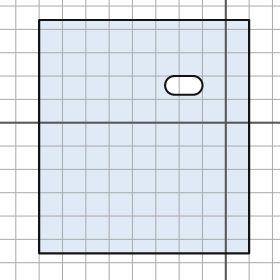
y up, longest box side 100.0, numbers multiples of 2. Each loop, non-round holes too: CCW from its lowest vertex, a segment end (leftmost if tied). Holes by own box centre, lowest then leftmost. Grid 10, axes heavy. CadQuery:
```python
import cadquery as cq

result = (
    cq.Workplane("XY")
    .moveTo(-80.0, -56.0)
    .lineTo(10.0, -56.0)
    .lineTo(10.0, 44.0)
    .lineTo(-80.0, 44.0)
    .close()
    .moveTo(-22.0, 12.0)
    .lineTo(-14.0, 12.0)
    .threePointArc((-10.0, 16.0), (-14.0, 20.0))
    .lineTo(-22.0, 20.0)
    .threePointArc((-26.0, 16.0), (-22.0, 12.0))
    .close()
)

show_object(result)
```